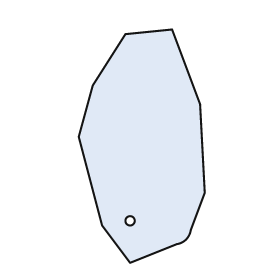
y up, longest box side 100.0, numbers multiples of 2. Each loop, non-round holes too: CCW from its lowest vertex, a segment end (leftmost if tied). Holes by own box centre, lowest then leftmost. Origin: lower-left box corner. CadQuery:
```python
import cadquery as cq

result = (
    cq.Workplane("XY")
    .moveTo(22.0, 0.0)
    .lineTo(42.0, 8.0)
    .threePointArc((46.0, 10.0), (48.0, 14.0))
    .lineTo(54.0, 30.0)
    .lineTo(52.0, 68.0)
    .lineTo(40.0, 100.0)
    .lineTo(20.0, 98.0)
    .lineTo(6.0, 76.0)
    .lineTo(0.0, 54.0)
    .lineTo(10.0, 16.0)
    .close()
    .moveTo(22.0, 18.0)
    .circle(2.0)
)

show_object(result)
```